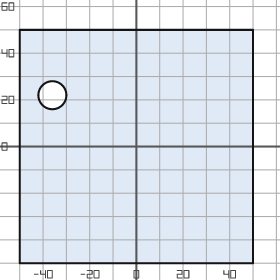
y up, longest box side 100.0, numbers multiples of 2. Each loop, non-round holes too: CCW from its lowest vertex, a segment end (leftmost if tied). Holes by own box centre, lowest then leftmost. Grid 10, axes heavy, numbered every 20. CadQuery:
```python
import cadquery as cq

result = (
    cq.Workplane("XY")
    .moveTo(-50.0, -50.0)
    .lineTo(50.0, -50.0)
    .lineTo(50.0, 50.0)
    .lineTo(-50.0, 50.0)
    .close()
    .moveTo(-36.0, 22.0)
    .circle(6.0)
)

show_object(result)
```